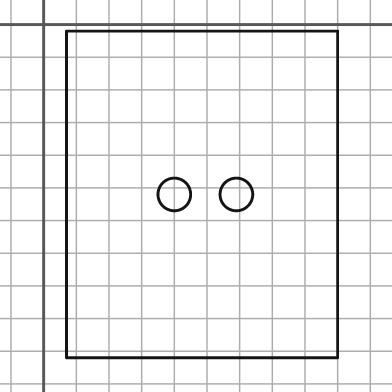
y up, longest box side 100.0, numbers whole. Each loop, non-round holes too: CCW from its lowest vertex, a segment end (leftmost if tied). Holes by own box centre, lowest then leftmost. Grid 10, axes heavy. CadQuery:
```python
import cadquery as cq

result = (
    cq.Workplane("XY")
    .moveTo(7.0, -102.0)
    .lineTo(90.0, -102.0)
    .lineTo(90.0, -2.0)
    .lineTo(7.0, -2.0)
    .close()
    .moveTo(40.0, -52.0)
    .circle(5.0)
    .moveTo(59.0, -52.0)
    .circle(5.0)
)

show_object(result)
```